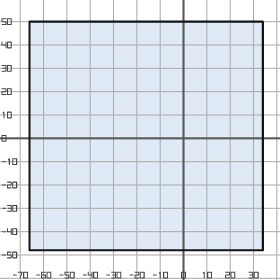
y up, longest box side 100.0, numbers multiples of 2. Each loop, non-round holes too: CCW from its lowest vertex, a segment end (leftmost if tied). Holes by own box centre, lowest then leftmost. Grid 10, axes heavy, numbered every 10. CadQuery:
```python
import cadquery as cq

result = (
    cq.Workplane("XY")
    .moveTo(-66.0, -48.0)
    .lineTo(34.0, -48.0)
    .lineTo(34.0, 50.0)
    .lineTo(-66.0, 50.0)
    .close()
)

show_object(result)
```